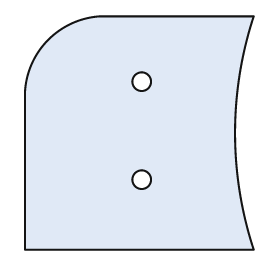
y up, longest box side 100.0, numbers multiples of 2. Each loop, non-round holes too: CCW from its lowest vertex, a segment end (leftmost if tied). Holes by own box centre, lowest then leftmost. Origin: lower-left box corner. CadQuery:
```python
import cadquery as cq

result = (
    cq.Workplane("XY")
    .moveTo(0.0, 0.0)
    .lineTo(98.0, 0.0)
    .threePointArc((90.0, 50.0), (98.0, 100.0))
    .lineTo(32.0, 100.0)
    .threePointArc((10.0, 90.0), (0.0, 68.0))
    .close()
    .moveTo(50.0, 30.0)
    .circle(4.0)
    .moveTo(50.0, 72.0)
    .circle(4.0)
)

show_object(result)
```